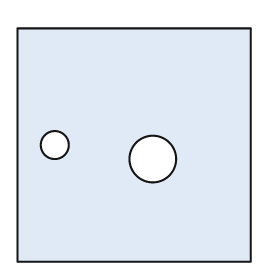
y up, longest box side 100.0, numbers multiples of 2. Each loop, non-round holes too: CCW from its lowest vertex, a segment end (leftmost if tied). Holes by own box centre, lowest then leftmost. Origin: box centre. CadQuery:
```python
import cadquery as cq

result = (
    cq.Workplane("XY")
    .moveTo(-50.0, -50.0)
    .lineTo(50.0, -50.0)
    .lineTo(50.0, 50.0)
    .lineTo(-50.0, 50.0)
    .close()
    .moveTo(8.0, -6.0)
    .circle(10.0)
    .moveTo(-34.0, 0.0)
    .circle(6.0)
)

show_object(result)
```